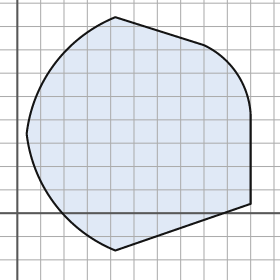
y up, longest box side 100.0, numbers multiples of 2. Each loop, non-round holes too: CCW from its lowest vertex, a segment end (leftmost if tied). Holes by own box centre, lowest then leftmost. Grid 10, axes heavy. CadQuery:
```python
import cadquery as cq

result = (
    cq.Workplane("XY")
    .moveTo(42.0, -16.0)
    .lineTo(100.0, 4.0)
    .lineTo(100.0, 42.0)
    .threePointArc((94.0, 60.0), (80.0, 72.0))
    .lineTo(42.0, 84.0)
    .threePointArc((16.0, 64.0), (4.0, 34.0))
    .threePointArc((16.0, 4.0), (42.0, -16.0))
    .close()
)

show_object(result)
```